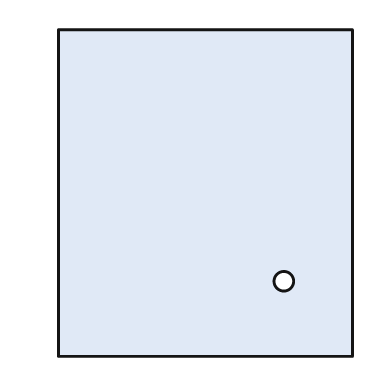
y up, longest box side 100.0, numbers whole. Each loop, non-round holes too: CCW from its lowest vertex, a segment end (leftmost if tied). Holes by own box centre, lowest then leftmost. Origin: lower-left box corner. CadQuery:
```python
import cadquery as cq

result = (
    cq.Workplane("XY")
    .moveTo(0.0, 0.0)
    .lineTo(90.0, 0.0)
    .lineTo(90.0, 100.0)
    .lineTo(0.0, 100.0)
    .close()
    .moveTo(69.0, 23.0)
    .circle(3.0)
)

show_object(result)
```